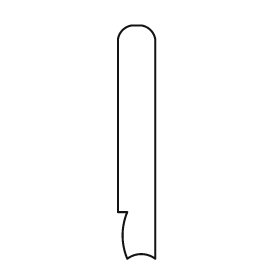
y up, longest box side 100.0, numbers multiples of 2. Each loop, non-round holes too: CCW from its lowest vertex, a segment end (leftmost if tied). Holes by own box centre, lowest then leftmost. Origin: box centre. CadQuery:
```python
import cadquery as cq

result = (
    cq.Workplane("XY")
    .moveTo(-4.0, -50.0)
    .threePointArc((2.0, -48.0), (8.0, -50.0))
    .lineTo(8.0, 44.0)
    .threePointArc((6.0, 48.0), (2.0, 50.0))
    .lineTo(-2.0, 50.0)
    .threePointArc((-6.0, 48.0), (-8.0, 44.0))
    .lineTo(-8.0, -30.0)
    .lineTo(-4.0, -30.0)
    .threePointArc((-6.0, -40.0), (-4.0, -50.0))
    .close()
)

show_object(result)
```